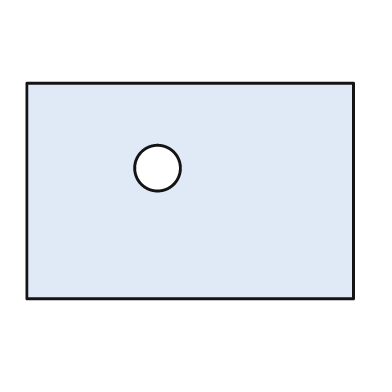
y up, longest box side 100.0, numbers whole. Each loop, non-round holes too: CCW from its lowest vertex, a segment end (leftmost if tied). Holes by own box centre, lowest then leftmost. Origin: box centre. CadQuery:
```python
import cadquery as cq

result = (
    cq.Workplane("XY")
    .moveTo(-50.0, -33.0)
    .lineTo(50.0, -33.0)
    .lineTo(50.0, 33.0)
    .lineTo(-50.0, 33.0)
    .close()
    .moveTo(-10.0, 7.0)
    .circle(7.0)
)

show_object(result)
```